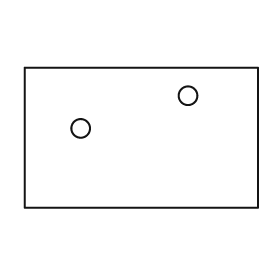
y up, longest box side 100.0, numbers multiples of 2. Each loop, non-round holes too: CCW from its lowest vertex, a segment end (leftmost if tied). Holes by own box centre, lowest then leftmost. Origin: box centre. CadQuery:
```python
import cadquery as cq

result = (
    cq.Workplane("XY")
    .moveTo(-50.0, -30.0)
    .lineTo(50.0, -30.0)
    .lineTo(50.0, 30.0)
    .lineTo(-50.0, 30.0)
    .close()
    .moveTo(-26.0, 4.0)
    .circle(4.0)
    .moveTo(20.0, 18.0)
    .circle(4.0)
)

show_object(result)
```